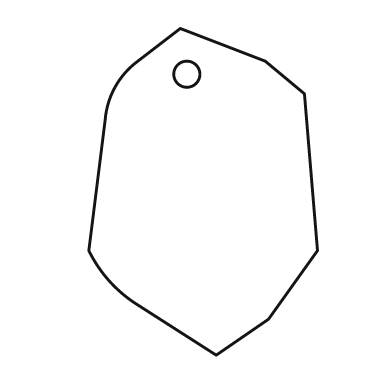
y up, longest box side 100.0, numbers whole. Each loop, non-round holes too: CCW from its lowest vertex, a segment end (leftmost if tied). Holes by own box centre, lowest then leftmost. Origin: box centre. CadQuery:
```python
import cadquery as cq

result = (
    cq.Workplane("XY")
    .moveTo(4.0, -50.0)
    .lineTo(20.0, -39.0)
    .lineTo(35.0, -18.0)
    .lineTo(31.0, 30.0)
    .lineTo(19.0, 40.0)
    .lineTo(-7.0, 50.0)
    .lineTo(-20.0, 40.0)
    .threePointArc((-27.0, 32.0), (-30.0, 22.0))
    .lineTo(-35.0, -18.0)
    .threePointArc((-29.0, -27.0), (-21.0, -34.0))
    .close()
    .moveTo(-5.0, 36.0)
    .circle(4.0)
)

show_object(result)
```